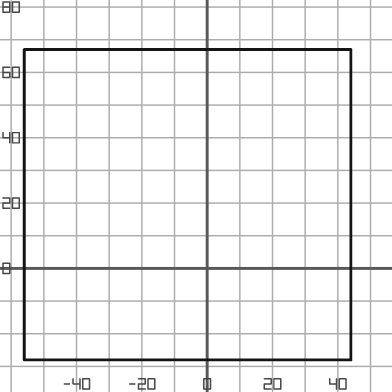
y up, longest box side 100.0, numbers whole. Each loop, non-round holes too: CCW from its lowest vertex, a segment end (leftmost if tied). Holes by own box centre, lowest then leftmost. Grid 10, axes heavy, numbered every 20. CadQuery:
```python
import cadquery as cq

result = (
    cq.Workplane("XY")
    .moveTo(-56.0, -28.0)
    .lineTo(44.0, -28.0)
    .lineTo(44.0, 67.0)
    .lineTo(-56.0, 67.0)
    .close()
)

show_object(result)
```